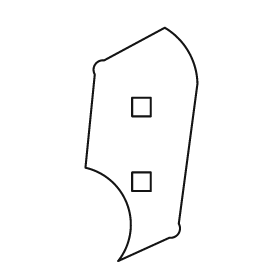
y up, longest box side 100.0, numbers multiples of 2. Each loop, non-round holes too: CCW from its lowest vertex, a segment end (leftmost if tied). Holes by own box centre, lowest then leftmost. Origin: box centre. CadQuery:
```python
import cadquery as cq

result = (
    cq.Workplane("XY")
    .moveTo(-10.0, -50.0)
    .lineTo(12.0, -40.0)
    .threePointArc((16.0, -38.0), (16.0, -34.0))
    .lineTo(24.0, 26.0)
    .threePointArc((20.0, 40.0), (10.0, 50.0))
    .lineTo(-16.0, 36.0)
    .threePointArc((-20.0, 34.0), (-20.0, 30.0))
    .lineTo(-24.0, -10.0)
    .threePointArc((-6.0, -26.0), (-10.0, -50.0))
    .close()
    .moveTo(-4.0, -20.0)
    .lineTo(4.0, -20.0)
    .lineTo(4.0, -12.0)
    .lineTo(-4.0, -12.0)
    .close()
    .moveTo(-4.0, 12.0)
    .lineTo(4.0, 12.0)
    .lineTo(4.0, 20.0)
    .lineTo(-4.0, 20.0)
    .close()
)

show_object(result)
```